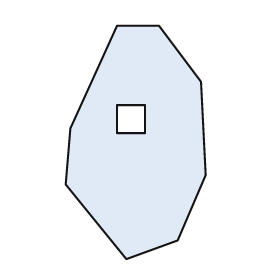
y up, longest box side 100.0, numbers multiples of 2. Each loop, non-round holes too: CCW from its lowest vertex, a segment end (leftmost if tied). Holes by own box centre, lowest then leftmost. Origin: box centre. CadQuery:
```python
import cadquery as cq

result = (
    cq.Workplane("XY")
    .moveTo(-4.0, -50.0)
    .lineTo(18.0, -42.0)
    .lineTo(30.0, -14.0)
    .lineTo(28.0, 26.0)
    .lineTo(10.0, 50.0)
    .lineTo(-8.0, 50.0)
    .lineTo(-28.0, 6.0)
    .lineTo(-30.0, -18.0)
    .close()
    .moveTo(-8.0, 4.0)
    .lineTo(4.0, 4.0)
    .lineTo(4.0, 16.0)
    .lineTo(-8.0, 16.0)
    .close()
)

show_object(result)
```